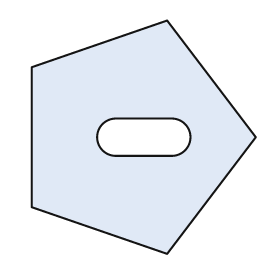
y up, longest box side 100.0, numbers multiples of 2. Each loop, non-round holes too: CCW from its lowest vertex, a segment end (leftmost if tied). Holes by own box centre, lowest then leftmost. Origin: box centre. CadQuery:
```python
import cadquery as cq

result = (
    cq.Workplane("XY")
    .moveTo(10.0, -50.0)
    .lineTo(48.0, 0.0)
    .lineTo(10.0, 50.0)
    .lineTo(-48.0, 30.0)
    .lineTo(-48.0, -30.0)
    .close()
    .moveTo(-12.0, -8.0)
    .lineTo(12.0, -8.0)
    .threePointArc((20.0, 0.0), (12.0, 8.0))
    .lineTo(-12.0, 8.0)
    .threePointArc((-20.0, 0.0), (-12.0, -8.0))
    .close()
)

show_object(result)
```